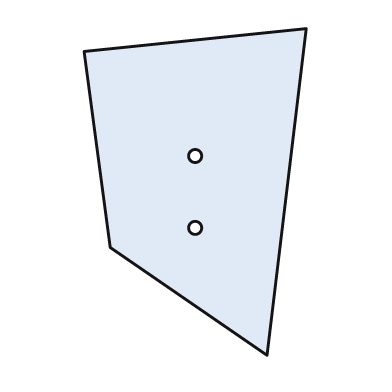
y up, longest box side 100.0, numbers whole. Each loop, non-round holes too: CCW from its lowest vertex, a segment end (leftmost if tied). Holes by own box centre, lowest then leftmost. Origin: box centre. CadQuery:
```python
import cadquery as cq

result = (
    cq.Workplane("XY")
    .moveTo(22.0, -50.0)
    .lineTo(34.0, 50.0)
    .lineTo(-34.0, 43.0)
    .lineTo(-26.0, -17.0)
    .close()
    .moveTo(0.0, -11.0)
    .circle(2.0)
    .moveTo(0.0, 11.0)
    .circle(2.0)
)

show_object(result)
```